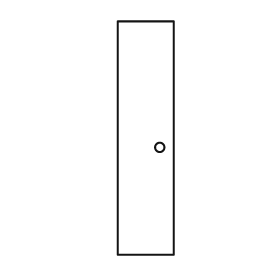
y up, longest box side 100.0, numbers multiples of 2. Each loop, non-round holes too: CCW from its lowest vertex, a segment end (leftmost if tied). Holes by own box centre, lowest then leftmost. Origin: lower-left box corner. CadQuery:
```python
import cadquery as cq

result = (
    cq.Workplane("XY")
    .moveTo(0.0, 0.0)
    .lineTo(24.0, 0.0)
    .lineTo(24.0, 100.0)
    .lineTo(0.0, 100.0)
    .close()
    .moveTo(18.0, 46.0)
    .circle(2.0)
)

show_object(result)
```